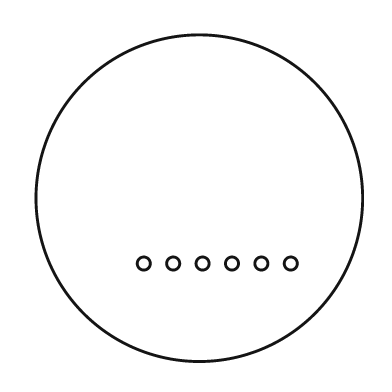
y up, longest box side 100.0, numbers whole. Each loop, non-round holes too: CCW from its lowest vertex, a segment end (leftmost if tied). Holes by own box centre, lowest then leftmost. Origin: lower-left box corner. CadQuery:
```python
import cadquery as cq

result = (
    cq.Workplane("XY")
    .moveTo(50.0, 50.0)
    .circle(50.0)
    .moveTo(33.0, 30.0)
    .circle(2.0)
    .moveTo(42.0, 30.0)
    .circle(2.0)
    .moveTo(51.0, 30.0)
    .circle(2.0)
    .moveTo(60.0, 30.0)
    .circle(2.0)
    .moveTo(69.0, 30.0)
    .circle(2.0)
    .moveTo(78.0, 30.0)
    .circle(2.0)
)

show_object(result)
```